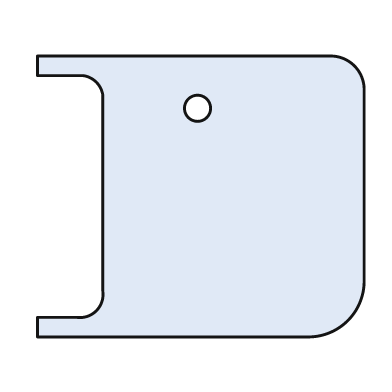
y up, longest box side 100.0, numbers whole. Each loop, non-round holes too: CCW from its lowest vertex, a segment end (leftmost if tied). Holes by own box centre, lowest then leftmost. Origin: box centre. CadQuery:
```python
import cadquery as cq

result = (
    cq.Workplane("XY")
    .moveTo(-50.0, -43.0)
    .lineTo(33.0, -43.0)
    .threePointArc((45.0, -38.0), (50.0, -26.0))
    .lineTo(50.0, 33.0)
    .threePointArc((47.0, 40.0), (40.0, 43.0))
    .lineTo(-50.0, 43.0)
    .lineTo(-50.0, 37.0)
    .lineTo(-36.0, 37.0)
    .threePointArc((-32.0, 35.0), (-30.0, 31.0))
    .lineTo(-30.0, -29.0)
    .threePointArc((-32.0, -35.0), (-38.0, -37.0))
    .lineTo(-50.0, -37.0)
    .close()
    .moveTo(-1.0, 27.0)
    .circle(4.0)
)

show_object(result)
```